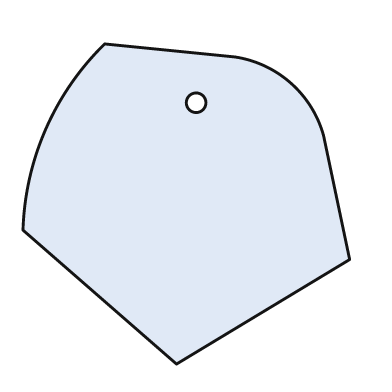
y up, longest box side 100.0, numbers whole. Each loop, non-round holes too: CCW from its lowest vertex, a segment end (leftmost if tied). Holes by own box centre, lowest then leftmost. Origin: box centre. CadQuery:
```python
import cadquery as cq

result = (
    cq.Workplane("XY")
    .moveTo(-3.0, -49.0)
    .lineTo(50.0, -17.0)
    .lineTo(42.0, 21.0)
    .threePointArc((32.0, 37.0), (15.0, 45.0))
    .lineTo(-25.0, 49.0)
    .threePointArc((-43.0, 23.0), (-50.0, -8.0))
    .close()
    .moveTo(3.0, 31.0)
    .circle(3.0)
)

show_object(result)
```